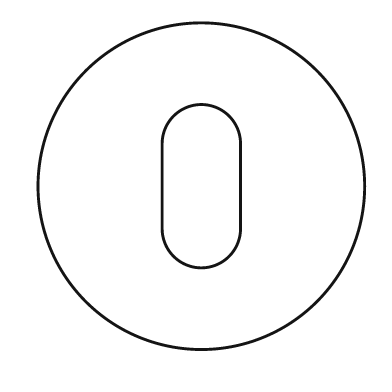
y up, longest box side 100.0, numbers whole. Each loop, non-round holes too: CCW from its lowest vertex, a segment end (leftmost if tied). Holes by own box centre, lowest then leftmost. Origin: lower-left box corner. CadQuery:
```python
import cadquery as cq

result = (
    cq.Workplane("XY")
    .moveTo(50.0, 50.0)
    .circle(50.0)
    .moveTo(38.0, 37.0)
    .threePointArc((50.0, 25.0), (62.0, 37.0))
    .lineTo(62.0, 63.0)
    .threePointArc((50.0, 75.0), (38.0, 63.0))
    .close()
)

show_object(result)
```